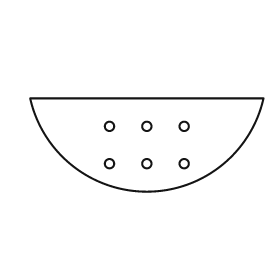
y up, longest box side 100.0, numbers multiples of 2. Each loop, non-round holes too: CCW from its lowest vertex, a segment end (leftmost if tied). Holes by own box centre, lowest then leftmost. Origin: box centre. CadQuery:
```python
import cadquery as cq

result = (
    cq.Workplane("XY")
    .moveTo(-50.0, 20.0)
    .threePointArc((0.0, -20.0), (50.0, 20.0))
    .close()
    .moveTo(-16.0, -8.0)
    .circle(2.0)
    .moveTo(0.0, -8.0)
    .circle(2.0)
    .moveTo(16.0, -8.0)
    .circle(2.0)
    .moveTo(-16.0, 8.0)
    .circle(2.0)
    .moveTo(0.0, 8.0)
    .circle(2.0)
    .moveTo(16.0, 8.0)
    .circle(2.0)
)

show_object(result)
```